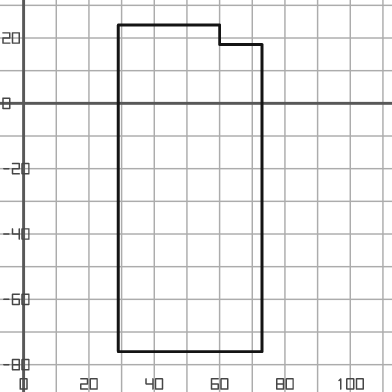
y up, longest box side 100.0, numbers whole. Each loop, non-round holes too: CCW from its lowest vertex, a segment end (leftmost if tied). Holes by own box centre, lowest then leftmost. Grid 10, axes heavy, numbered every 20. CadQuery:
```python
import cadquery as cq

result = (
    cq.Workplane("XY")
    .moveTo(29.0, -76.0)
    .lineTo(73.0, -76.0)
    .lineTo(73.0, 18.0)
    .lineTo(60.0, 18.0)
    .lineTo(60.0, 24.0)
    .lineTo(29.0, 24.0)
    .close()
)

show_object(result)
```